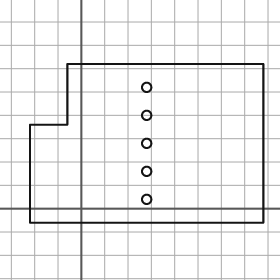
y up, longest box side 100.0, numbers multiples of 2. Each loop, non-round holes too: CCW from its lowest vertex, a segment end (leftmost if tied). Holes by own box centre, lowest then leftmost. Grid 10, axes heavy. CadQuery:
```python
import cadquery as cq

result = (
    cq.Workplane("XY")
    .moveTo(-22.0, -6.0)
    .lineTo(78.0, -6.0)
    .lineTo(78.0, 62.0)
    .lineTo(-6.0, 62.0)
    .lineTo(-6.0, 36.0)
    .lineTo(-22.0, 36.0)
    .close()
    .moveTo(28.0, 4.0)
    .circle(2.0)
    .moveTo(28.0, 16.0)
    .circle(2.0)
    .moveTo(28.0, 28.0)
    .circle(2.0)
    .moveTo(28.0, 40.0)
    .circle(2.0)
    .moveTo(28.0, 52.0)
    .circle(2.0)
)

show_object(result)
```